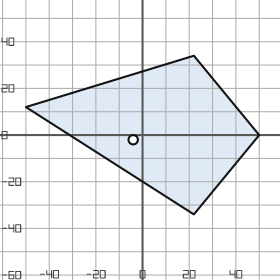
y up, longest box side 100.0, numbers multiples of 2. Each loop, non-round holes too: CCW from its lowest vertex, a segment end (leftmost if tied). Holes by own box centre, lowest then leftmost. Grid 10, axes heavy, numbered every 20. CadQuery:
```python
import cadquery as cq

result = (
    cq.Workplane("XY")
    .moveTo(22.0, -34.0)
    .lineTo(50.0, 0.0)
    .lineTo(22.0, 34.0)
    .lineTo(-50.0, 12.0)
    .close()
    .moveTo(-4.0, -2.0)
    .circle(2.0)
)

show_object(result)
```